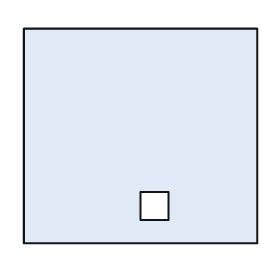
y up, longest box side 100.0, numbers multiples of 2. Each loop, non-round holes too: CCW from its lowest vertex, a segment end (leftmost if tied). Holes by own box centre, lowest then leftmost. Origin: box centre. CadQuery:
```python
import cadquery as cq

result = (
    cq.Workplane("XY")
    .moveTo(-50.0, -46.0)
    .lineTo(50.0, -46.0)
    .lineTo(50.0, 46.0)
    .lineTo(-50.0, 46.0)
    .close()
    .moveTo(0.0, -36.0)
    .lineTo(12.0, -36.0)
    .lineTo(12.0, -24.0)
    .lineTo(0.0, -24.0)
    .close()
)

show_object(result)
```